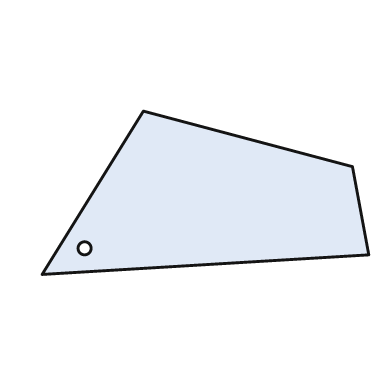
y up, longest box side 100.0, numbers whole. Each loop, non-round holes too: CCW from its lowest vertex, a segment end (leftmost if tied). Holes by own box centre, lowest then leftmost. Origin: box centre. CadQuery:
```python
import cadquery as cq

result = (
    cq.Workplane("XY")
    .moveTo(-50.0, -25.0)
    .lineTo(50.0, -19.0)
    .lineTo(45.0, 8.0)
    .lineTo(-19.0, 25.0)
    .close()
    .moveTo(-37.0, -17.0)
    .circle(2.0)
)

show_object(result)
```